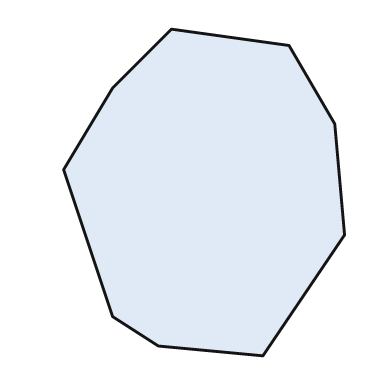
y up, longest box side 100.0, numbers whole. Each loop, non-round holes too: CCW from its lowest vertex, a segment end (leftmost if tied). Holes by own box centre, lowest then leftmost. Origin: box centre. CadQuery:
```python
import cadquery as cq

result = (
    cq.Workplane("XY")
    .moveTo(18.0, -50.0)
    .lineTo(43.0, -13.0)
    .lineTo(40.0, 21.0)
    .lineTo(26.0, 45.0)
    .lineTo(-10.0, 50.0)
    .lineTo(-28.0, 32.0)
    .lineTo(-43.0, 7.0)
    .lineTo(-28.0, -38.0)
    .lineTo(-14.0, -47.0)
    .close()
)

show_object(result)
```